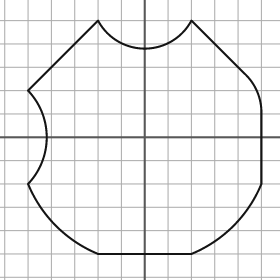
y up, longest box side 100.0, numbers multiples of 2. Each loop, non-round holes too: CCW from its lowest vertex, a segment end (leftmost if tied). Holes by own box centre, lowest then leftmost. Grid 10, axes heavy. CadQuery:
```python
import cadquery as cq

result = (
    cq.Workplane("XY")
    .moveTo(-20.0, -50.0)
    .lineTo(20.0, -50.0)
    .threePointArc((38.0, -38.0), (50.0, -20.0))
    .lineTo(50.0, 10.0)
    .threePointArc((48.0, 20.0), (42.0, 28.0))
    .lineTo(20.0, 50.0)
    .threePointArc((0.0, 38.0), (-20.0, 50.0))
    .lineTo(-50.0, 20.0)
    .threePointArc((-42.0, 0.0), (-50.0, -20.0))
    .threePointArc((-38.0, -38.0), (-20.0, -50.0))
    .close()
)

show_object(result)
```